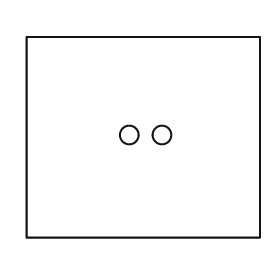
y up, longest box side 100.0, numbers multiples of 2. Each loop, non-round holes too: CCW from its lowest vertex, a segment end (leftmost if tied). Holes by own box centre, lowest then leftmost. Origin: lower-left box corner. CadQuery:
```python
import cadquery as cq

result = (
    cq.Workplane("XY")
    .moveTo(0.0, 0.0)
    .lineTo(100.0, 0.0)
    .lineTo(100.0, 86.0)
    .lineTo(0.0, 86.0)
    .close()
    .moveTo(44.0, 44.0)
    .circle(4.0)
    .moveTo(58.0, 44.0)
    .circle(4.0)
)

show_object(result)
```